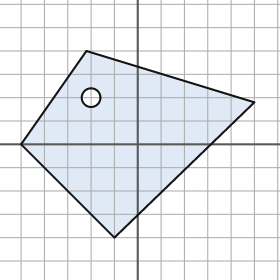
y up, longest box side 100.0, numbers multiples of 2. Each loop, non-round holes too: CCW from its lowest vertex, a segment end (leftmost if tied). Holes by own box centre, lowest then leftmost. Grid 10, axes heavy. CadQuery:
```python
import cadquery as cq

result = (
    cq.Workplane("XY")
    .moveTo(-10.0, -40.0)
    .lineTo(50.0, 18.0)
    .lineTo(-22.0, 40.0)
    .lineTo(-50.0, 0.0)
    .close()
    .moveTo(-20.0, 20.0)
    .circle(4.0)
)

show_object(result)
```